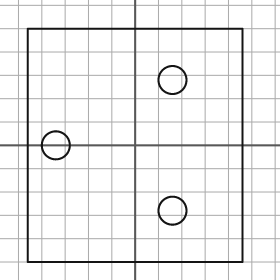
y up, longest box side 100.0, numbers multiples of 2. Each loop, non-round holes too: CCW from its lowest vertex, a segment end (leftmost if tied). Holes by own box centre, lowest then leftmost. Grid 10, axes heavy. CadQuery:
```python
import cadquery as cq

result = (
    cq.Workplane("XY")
    .moveTo(-46.0, -50.0)
    .lineTo(46.0, -50.0)
    .lineTo(46.0, 50.0)
    .lineTo(-46.0, 50.0)
    .close()
    .moveTo(16.0, -28.0)
    .circle(6.0)
    .moveTo(-34.0, 0.0)
    .circle(6.0)
    .moveTo(16.0, 28.0)
    .circle(6.0)
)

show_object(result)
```